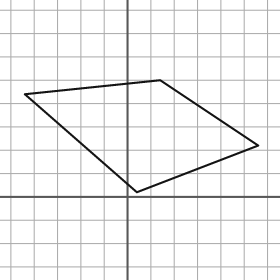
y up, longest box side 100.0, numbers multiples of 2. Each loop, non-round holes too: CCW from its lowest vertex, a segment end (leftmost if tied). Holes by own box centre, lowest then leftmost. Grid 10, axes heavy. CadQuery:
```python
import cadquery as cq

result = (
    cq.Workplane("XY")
    .moveTo(4.0, 2.0)
    .lineTo(56.0, 22.0)
    .lineTo(14.0, 50.0)
    .lineTo(-44.0, 44.0)
    .close()
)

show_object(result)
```